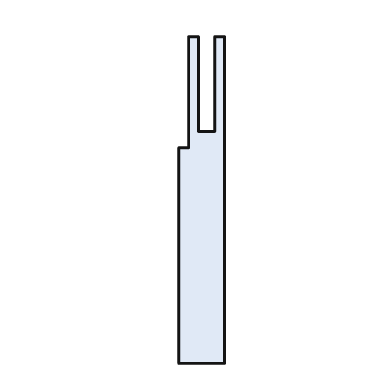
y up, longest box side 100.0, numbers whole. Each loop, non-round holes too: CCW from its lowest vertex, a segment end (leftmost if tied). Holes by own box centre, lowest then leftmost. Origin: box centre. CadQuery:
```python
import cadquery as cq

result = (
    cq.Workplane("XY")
    .moveTo(-7.0, -50.0)
    .lineTo(7.0, -50.0)
    .lineTo(7.0, 50.0)
    .lineTo(4.0, 50.0)
    .lineTo(4.0, 21.0)
    .lineTo(-1.0, 21.0)
    .lineTo(-1.0, 50.0)
    .lineTo(-4.0, 50.0)
    .lineTo(-4.0, 16.0)
    .lineTo(-7.0, 16.0)
    .close()
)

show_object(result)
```